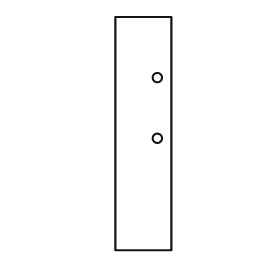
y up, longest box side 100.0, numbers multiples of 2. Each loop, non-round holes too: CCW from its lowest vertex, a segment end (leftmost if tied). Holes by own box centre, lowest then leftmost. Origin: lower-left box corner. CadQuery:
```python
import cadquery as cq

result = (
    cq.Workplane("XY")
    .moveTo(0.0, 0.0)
    .lineTo(24.0, 0.0)
    .lineTo(24.0, 100.0)
    .lineTo(0.0, 100.0)
    .close()
    .moveTo(18.0, 48.0)
    .circle(2.0)
    .moveTo(18.0, 74.0)
    .circle(2.0)
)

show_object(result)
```